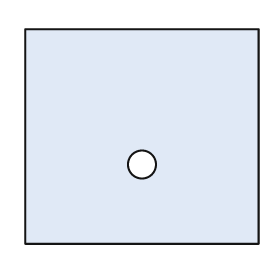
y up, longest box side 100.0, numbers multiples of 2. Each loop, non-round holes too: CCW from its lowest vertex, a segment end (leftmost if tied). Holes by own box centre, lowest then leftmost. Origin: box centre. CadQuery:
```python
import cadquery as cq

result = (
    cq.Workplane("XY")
    .moveTo(-50.0, -46.0)
    .lineTo(50.0, -46.0)
    .lineTo(50.0, 46.0)
    .lineTo(-50.0, 46.0)
    .close()
    .moveTo(0.0, -12.0)
    .circle(6.0)
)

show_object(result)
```